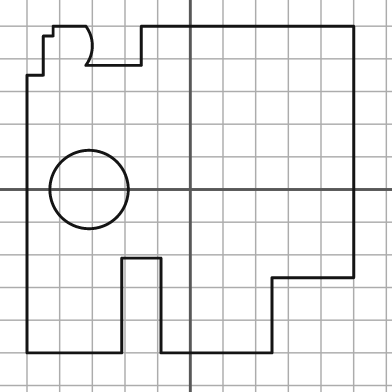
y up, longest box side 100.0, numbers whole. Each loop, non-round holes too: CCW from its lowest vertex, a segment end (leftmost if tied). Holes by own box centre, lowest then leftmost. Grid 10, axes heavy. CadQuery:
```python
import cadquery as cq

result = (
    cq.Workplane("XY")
    .moveTo(-50.0, -50.0)
    .lineTo(-21.0, -50.0)
    .lineTo(-21.0, -21.0)
    .lineTo(-9.0, -21.0)
    .lineTo(-9.0, -50.0)
    .lineTo(25.0, -50.0)
    .lineTo(25.0, -27.0)
    .lineTo(50.0, -27.0)
    .lineTo(50.0, 50.0)
    .lineTo(-15.0, 50.0)
    .lineTo(-15.0, 38.0)
    .lineTo(-32.0, 38.0)
    .threePointArc((-30.0, 44.0), (-32.0, 50.0))
    .lineTo(-42.0, 50.0)
    .lineTo(-42.0, 47.0)
    .lineTo(-45.0, 47.0)
    .lineTo(-45.0, 35.0)
    .lineTo(-50.0, 35.0)
    .close()
    .moveTo(-31.0, 0.0)
    .circle(12.0)
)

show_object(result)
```